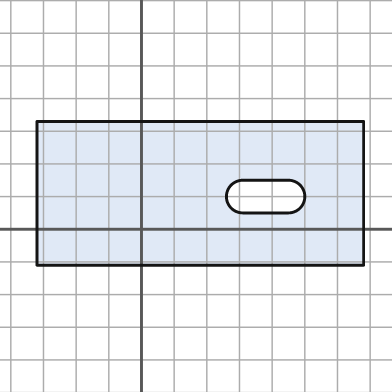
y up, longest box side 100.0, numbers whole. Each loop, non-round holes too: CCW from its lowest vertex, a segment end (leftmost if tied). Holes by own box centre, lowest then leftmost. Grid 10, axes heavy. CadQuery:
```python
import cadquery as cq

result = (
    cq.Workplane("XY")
    .moveTo(-32.0, -11.0)
    .lineTo(68.0, -11.0)
    .lineTo(68.0, 33.0)
    .lineTo(-32.0, 33.0)
    .close()
    .moveTo(31.0, 5.0)
    .lineTo(45.0, 5.0)
    .threePointArc((50.0, 10.0), (45.0, 15.0))
    .lineTo(31.0, 15.0)
    .threePointArc((26.0, 10.0), (31.0, 5.0))
    .close()
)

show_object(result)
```